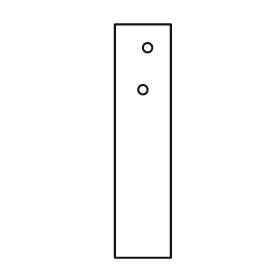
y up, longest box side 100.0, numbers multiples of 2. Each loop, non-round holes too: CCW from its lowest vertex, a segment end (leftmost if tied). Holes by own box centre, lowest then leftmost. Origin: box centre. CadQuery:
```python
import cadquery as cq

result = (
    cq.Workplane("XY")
    .moveTo(-12.0, -50.0)
    .lineTo(12.0, -50.0)
    .lineTo(12.0, 50.0)
    .lineTo(-12.0, 50.0)
    .close()
    .moveTo(0.0, 22.0)
    .circle(2.0)
    .moveTo(2.0, 40.0)
    .circle(2.0)
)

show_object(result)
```